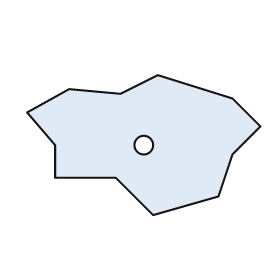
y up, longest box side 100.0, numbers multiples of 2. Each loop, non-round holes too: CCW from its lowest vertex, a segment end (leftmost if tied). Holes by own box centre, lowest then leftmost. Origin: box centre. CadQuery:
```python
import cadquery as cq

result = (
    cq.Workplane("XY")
    .moveTo(4.0, -30.0)
    .lineTo(32.0, -22.0)
    .lineTo(38.0, -4.0)
    .lineTo(50.0, 8.0)
    .lineTo(38.0, 20.0)
    .lineTo(6.0, 30.0)
    .lineTo(-10.0, 22.0)
    .lineTo(-32.0, 24.0)
    .lineTo(-50.0, 14.0)
    .lineTo(-38.0, 0.0)
    .lineTo(-38.0, -14.0)
    .lineTo(-12.0, -14.0)
    .close()
    .moveTo(0.0, 0.0)
    .circle(4.0)
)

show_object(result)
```